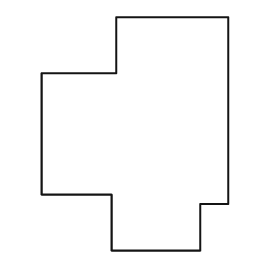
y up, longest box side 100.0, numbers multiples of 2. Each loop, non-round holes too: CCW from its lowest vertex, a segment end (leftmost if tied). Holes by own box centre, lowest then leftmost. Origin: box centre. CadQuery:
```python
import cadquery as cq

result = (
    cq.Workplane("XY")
    .moveTo(-10.0, -50.0)
    .lineTo(28.0, -50.0)
    .lineTo(28.0, -30.0)
    .lineTo(40.0, -30.0)
    .lineTo(40.0, 50.0)
    .lineTo(-8.0, 50.0)
    .lineTo(-8.0, 26.0)
    .lineTo(-40.0, 26.0)
    .lineTo(-40.0, -26.0)
    .lineTo(-10.0, -26.0)
    .close()
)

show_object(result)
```